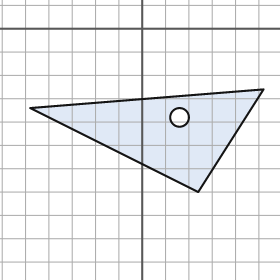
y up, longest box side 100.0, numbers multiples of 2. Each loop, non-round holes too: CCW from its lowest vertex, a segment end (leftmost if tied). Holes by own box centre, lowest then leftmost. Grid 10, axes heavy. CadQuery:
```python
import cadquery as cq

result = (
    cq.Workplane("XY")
    .moveTo(24.0, -70.0)
    .lineTo(52.0, -26.0)
    .lineTo(-48.0, -34.0)
    .close()
    .moveTo(16.0, -38.0)
    .circle(4.0)
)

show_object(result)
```